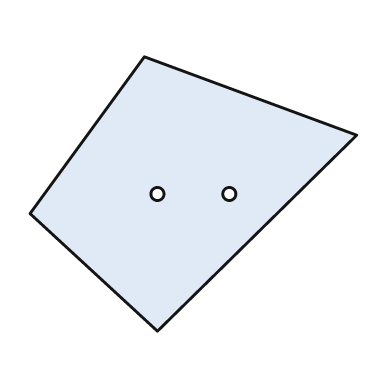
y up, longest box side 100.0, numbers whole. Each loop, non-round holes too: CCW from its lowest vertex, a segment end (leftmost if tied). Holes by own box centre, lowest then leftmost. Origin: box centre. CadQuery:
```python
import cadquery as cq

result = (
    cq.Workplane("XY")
    .moveTo(-11.0, -42.0)
    .lineTo(50.0, 18.0)
    .lineTo(-15.0, 42.0)
    .lineTo(-50.0, -6.0)
    .close()
    .moveTo(-11.0, 0.0)
    .circle(2.0)
    .moveTo(11.0, 0.0)
    .circle(2.0)
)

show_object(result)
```